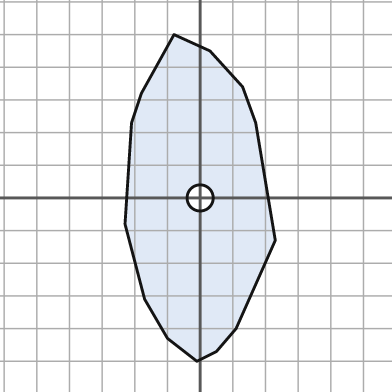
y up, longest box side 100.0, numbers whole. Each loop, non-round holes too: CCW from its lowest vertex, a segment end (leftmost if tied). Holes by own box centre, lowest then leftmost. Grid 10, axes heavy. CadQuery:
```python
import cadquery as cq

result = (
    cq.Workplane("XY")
    .moveTo(-1.0, -50.0)
    .lineTo(5.0, -47.0)
    .lineTo(11.0, -40.0)
    .lineTo(23.0, -13.0)
    .lineTo(17.0, 23.0)
    .lineTo(13.0, 34.0)
    .lineTo(3.0, 45.0)
    .lineTo(-8.0, 50.0)
    .lineTo(-18.0, 32.0)
    .lineTo(-21.0, 23.0)
    .lineTo(-23.0, -8.0)
    .lineTo(-17.0, -31.0)
    .lineTo(-10.0, -43.0)
    .close()
    .moveTo(0.0, 0.0)
    .circle(4.0)
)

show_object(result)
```